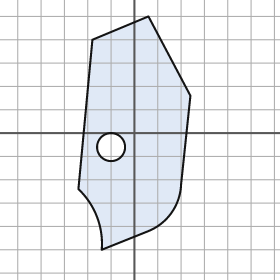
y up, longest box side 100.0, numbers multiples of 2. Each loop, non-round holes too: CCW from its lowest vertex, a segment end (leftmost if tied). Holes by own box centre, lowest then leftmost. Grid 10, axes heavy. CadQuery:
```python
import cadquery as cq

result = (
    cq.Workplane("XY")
    .moveTo(-14.0, -50.0)
    .lineTo(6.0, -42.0)
    .threePointArc((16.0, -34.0), (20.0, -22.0))
    .lineTo(24.0, 16.0)
    .lineTo(6.0, 50.0)
    .lineTo(-18.0, 40.0)
    .lineTo(-24.0, -24.0)
    .threePointArc((-16.0, -36.0), (-14.0, -50.0))
    .close()
    .moveTo(-10.0, -6.0)
    .circle(6.0)
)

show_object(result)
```